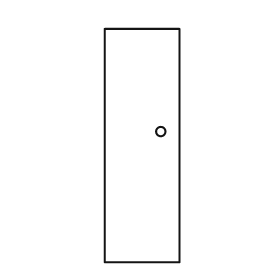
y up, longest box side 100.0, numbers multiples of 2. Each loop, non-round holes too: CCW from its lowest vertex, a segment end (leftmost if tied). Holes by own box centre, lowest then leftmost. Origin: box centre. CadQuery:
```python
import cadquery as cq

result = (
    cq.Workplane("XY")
    .moveTo(-16.0, -50.0)
    .lineTo(16.0, -50.0)
    .lineTo(16.0, 50.0)
    .lineTo(-16.0, 50.0)
    .close()
    .moveTo(8.0, 6.0)
    .circle(2.0)
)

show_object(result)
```